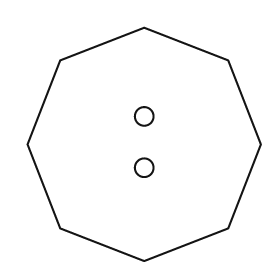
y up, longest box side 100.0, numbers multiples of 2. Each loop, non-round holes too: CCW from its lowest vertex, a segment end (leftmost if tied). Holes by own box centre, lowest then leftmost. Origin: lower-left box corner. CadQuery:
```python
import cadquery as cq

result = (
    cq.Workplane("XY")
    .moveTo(50.0, 0.0)
    .lineTo(86.0, 14.0)
    .lineTo(100.0, 50.0)
    .lineTo(86.0, 86.0)
    .lineTo(50.0, 100.0)
    .lineTo(14.0, 86.0)
    .lineTo(0.0, 50.0)
    .lineTo(14.0, 14.0)
    .close()
    .moveTo(50.0, 40.0)
    .circle(4.0)
    .moveTo(50.0, 62.0)
    .circle(4.0)
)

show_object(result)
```